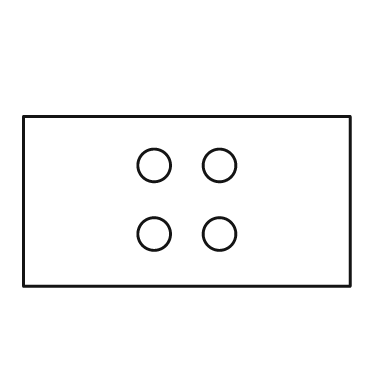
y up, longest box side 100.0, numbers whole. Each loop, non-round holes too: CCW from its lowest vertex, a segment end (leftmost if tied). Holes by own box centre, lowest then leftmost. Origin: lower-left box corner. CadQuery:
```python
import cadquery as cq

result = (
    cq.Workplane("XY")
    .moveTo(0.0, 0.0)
    .lineTo(100.0, 0.0)
    .lineTo(100.0, 52.0)
    .lineTo(0.0, 52.0)
    .close()
    .moveTo(40.0, 16.0)
    .circle(5.0)
    .moveTo(60.0, 16.0)
    .circle(5.0)
    .moveTo(40.0, 37.0)
    .circle(5.0)
    .moveTo(60.0, 37.0)
    .circle(5.0)
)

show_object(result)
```